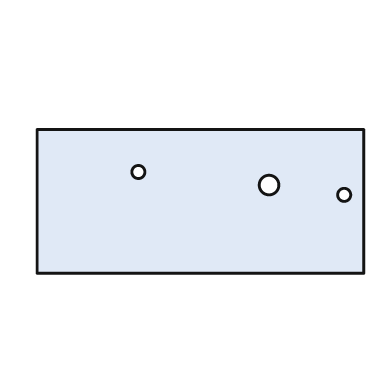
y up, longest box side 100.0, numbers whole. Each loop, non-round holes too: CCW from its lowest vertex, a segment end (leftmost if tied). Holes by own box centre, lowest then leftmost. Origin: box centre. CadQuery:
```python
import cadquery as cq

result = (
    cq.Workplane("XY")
    .moveTo(-50.0, -22.0)
    .lineTo(50.0, -22.0)
    .lineTo(50.0, 22.0)
    .lineTo(-50.0, 22.0)
    .close()
    .moveTo(44.0, 2.0)
    .circle(2.0)
    .moveTo(21.0, 5.0)
    .circle(3.0)
    .moveTo(-19.0, 9.0)
    .circle(2.0)
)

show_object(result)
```